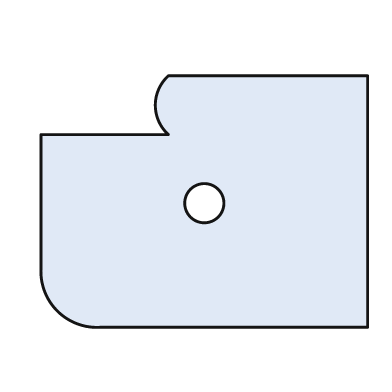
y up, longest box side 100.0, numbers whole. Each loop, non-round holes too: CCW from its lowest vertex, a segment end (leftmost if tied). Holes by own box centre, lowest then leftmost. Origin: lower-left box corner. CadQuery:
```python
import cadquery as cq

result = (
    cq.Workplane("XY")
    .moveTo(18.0, 0.0)
    .lineTo(100.0, 0.0)
    .lineTo(100.0, 77.0)
    .lineTo(39.0, 77.0)
    .threePointArc((35.0, 68.0), (39.0, 59.0))
    .lineTo(0.0, 59.0)
    .lineTo(0.0, 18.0)
    .threePointArc((5.0, 5.0), (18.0, 0.0))
    .close()
    .moveTo(50.0, 38.0)
    .circle(6.0)
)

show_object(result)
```